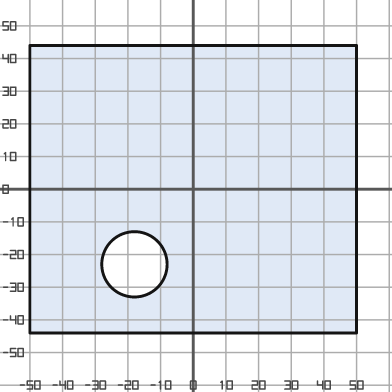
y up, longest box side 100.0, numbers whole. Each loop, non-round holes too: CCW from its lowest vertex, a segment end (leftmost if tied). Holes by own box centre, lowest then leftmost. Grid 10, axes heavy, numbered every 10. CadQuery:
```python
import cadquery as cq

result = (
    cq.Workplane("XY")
    .moveTo(-50.0, -44.0)
    .lineTo(50.0, -44.0)
    .lineTo(50.0, 44.0)
    .lineTo(-50.0, 44.0)
    .close()
    .moveTo(-18.0, -23.0)
    .circle(10.0)
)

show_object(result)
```